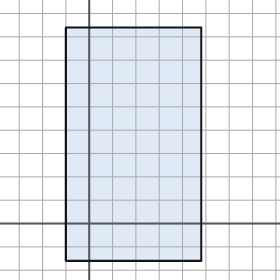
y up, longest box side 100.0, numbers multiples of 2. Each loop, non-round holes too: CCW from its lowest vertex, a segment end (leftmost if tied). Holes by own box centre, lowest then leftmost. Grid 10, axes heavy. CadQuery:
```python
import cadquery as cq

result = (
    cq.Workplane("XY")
    .moveTo(-10.0, -16.0)
    .lineTo(48.0, -16.0)
    .lineTo(48.0, 84.0)
    .lineTo(-10.0, 84.0)
    .close()
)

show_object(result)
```